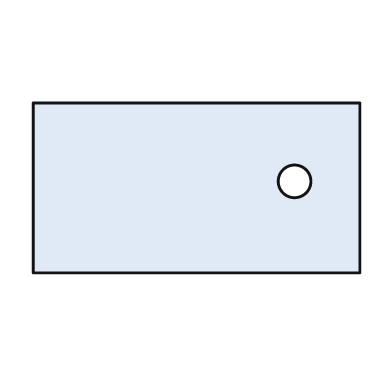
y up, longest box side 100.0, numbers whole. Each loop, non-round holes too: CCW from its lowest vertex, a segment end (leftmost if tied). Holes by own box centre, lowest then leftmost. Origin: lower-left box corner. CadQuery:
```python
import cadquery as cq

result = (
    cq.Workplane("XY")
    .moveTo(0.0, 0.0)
    .lineTo(100.0, 0.0)
    .lineTo(100.0, 52.0)
    .lineTo(0.0, 52.0)
    .close()
    .moveTo(80.0, 28.0)
    .circle(5.0)
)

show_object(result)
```